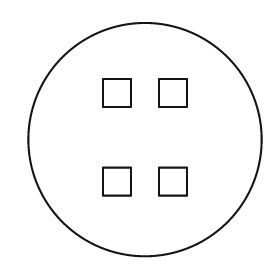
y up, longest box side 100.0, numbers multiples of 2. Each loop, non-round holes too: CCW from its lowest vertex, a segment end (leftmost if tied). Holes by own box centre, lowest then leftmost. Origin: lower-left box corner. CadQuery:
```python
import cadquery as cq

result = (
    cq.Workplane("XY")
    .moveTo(50.0, 50.0)
    .circle(50.0)
    .moveTo(32.0, 26.0)
    .lineTo(44.0, 26.0)
    .lineTo(44.0, 38.0)
    .lineTo(32.0, 38.0)
    .close()
    .moveTo(56.0, 26.0)
    .lineTo(68.0, 26.0)
    .lineTo(68.0, 38.0)
    .lineTo(56.0, 38.0)
    .close()
    .moveTo(32.0, 64.0)
    .lineTo(44.0, 64.0)
    .lineTo(44.0, 76.0)
    .lineTo(32.0, 76.0)
    .close()
    .moveTo(56.0, 64.0)
    .lineTo(68.0, 64.0)
    .lineTo(68.0, 76.0)
    .lineTo(56.0, 76.0)
    .close()
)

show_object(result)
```